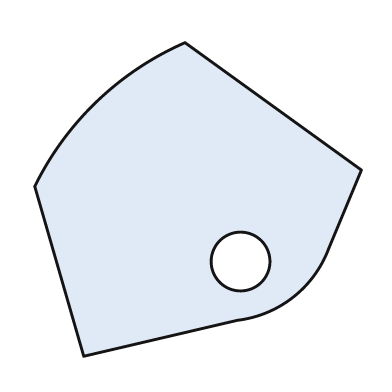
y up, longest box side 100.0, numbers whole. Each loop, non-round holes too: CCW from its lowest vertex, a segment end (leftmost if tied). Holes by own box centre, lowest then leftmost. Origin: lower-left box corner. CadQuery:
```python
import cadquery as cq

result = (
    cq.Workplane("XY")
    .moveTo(15.0, 0.0)
    .lineTo(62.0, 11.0)
    .threePointArc((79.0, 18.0), (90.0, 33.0))
    .lineTo(100.0, 57.0)
    .lineTo(46.0, 96.0)
    .threePointArc((19.0, 78.0), (0.0, 52.0))
    .close()
    .moveTo(63.0, 29.0)
    .circle(9.0)
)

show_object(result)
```